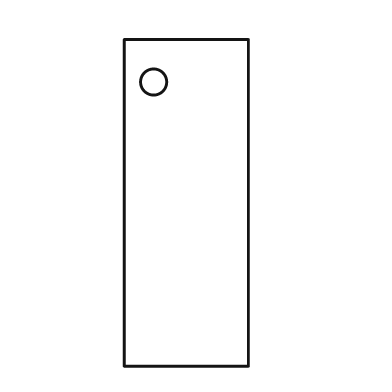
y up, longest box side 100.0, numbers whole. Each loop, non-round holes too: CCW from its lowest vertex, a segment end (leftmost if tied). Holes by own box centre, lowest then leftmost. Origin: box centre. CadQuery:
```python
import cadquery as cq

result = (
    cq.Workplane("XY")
    .moveTo(-19.0, -50.0)
    .lineTo(19.0, -50.0)
    .lineTo(19.0, 50.0)
    .lineTo(-19.0, 50.0)
    .close()
    .moveTo(-10.0, 37.0)
    .circle(4.0)
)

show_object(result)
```